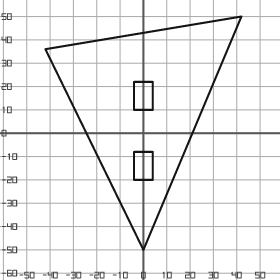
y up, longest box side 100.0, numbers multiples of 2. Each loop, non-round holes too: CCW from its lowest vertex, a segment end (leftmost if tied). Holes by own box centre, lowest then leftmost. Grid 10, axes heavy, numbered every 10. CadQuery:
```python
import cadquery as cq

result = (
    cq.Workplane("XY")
    .moveTo(0.0, -50.0)
    .lineTo(42.0, 50.0)
    .lineTo(-42.0, 36.0)
    .close()
    .moveTo(-4.0, -20.0)
    .lineTo(4.0, -20.0)
    .lineTo(4.0, -8.0)
    .lineTo(-4.0, -8.0)
    .close()
    .moveTo(-4.0, 10.0)
    .lineTo(4.0, 10.0)
    .lineTo(4.0, 22.0)
    .lineTo(-4.0, 22.0)
    .close()
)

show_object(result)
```